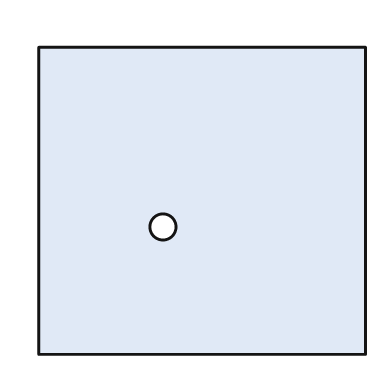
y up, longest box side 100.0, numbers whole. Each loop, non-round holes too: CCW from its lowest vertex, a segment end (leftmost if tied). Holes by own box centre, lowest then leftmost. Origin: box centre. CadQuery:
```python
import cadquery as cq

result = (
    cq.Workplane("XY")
    .moveTo(-50.0, -47.0)
    .lineTo(50.0, -47.0)
    .lineTo(50.0, 47.0)
    .lineTo(-50.0, 47.0)
    .close()
    .moveTo(-12.0, -8.0)
    .circle(4.0)
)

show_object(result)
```